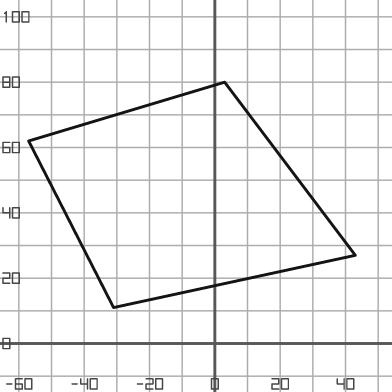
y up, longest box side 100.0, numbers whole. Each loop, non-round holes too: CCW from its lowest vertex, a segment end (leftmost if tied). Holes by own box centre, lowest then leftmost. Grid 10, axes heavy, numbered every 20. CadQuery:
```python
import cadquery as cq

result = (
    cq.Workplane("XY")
    .moveTo(-31.0, 11.0)
    .lineTo(43.0, 27.0)
    .lineTo(3.0, 80.0)
    .lineTo(-57.0, 62.0)
    .close()
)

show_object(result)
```